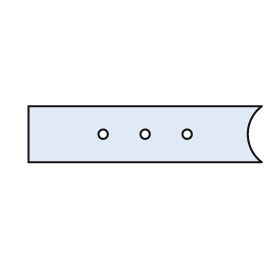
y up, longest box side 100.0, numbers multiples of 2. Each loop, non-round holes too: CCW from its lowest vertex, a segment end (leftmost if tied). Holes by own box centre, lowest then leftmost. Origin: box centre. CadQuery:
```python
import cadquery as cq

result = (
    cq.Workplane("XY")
    .moveTo(-50.0, -12.0)
    .lineTo(50.0, -12.0)
    .threePointArc((44.0, 0.0), (50.0, 12.0))
    .lineTo(-50.0, 12.0)
    .close()
    .moveTo(-18.0, 0.0)
    .circle(2.0)
    .moveTo(0.0, 0.0)
    .circle(2.0)
    .moveTo(18.0, 0.0)
    .circle(2.0)
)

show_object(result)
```